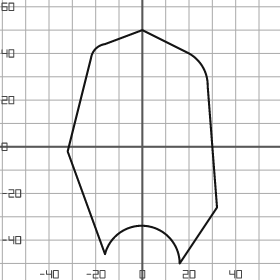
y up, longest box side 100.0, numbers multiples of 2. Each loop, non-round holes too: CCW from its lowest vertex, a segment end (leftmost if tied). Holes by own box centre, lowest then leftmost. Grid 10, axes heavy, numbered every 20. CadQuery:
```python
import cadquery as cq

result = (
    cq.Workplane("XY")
    .moveTo(16.0, -50.0)
    .lineTo(32.0, -26.0)
    .lineTo(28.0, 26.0)
    .threePointArc((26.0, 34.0), (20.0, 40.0))
    .lineTo(0.0, 50.0)
    .lineTo(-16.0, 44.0)
    .threePointArc((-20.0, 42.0), (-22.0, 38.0))
    .lineTo(-32.0, -2.0)
    .lineTo(-16.0, -46.0)
    .threePointArc((2.0, -34.0), (16.0, -50.0))
    .close()
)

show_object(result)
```